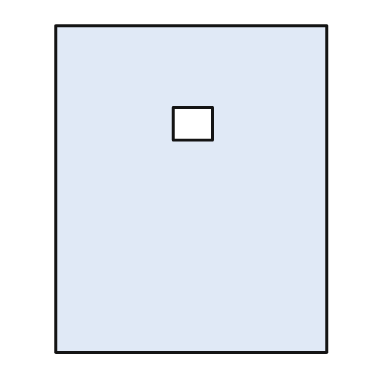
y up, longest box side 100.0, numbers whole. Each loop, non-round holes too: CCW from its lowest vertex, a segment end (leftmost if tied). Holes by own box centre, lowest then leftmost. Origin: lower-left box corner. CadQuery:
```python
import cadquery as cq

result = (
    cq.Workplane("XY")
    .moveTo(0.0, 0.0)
    .lineTo(83.0, 0.0)
    .lineTo(83.0, 100.0)
    .lineTo(0.0, 100.0)
    .close()
    .moveTo(36.0, 65.0)
    .lineTo(48.0, 65.0)
    .lineTo(48.0, 75.0)
    .lineTo(36.0, 75.0)
    .close()
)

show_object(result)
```